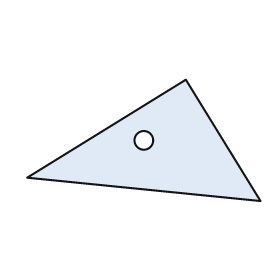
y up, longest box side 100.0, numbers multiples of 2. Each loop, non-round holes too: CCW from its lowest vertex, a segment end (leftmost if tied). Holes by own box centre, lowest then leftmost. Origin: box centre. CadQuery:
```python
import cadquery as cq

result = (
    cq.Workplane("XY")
    .moveTo(50.0, -26.0)
    .lineTo(18.0, 26.0)
    .lineTo(-50.0, -16.0)
    .close()
    .moveTo(0.0, 0.0)
    .circle(4.0)
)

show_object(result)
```